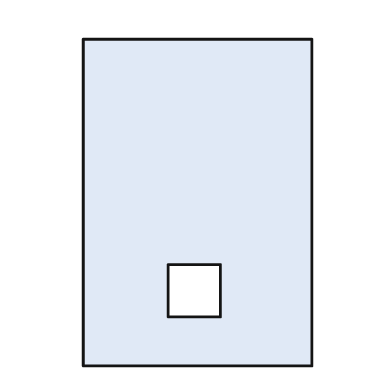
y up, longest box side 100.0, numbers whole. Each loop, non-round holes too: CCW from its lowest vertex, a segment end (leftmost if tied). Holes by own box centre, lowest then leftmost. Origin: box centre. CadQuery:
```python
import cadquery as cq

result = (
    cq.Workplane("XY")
    .moveTo(-35.0, -50.0)
    .lineTo(35.0, -50.0)
    .lineTo(35.0, 50.0)
    .lineTo(-35.0, 50.0)
    .close()
    .moveTo(-9.0, -35.0)
    .lineTo(7.0, -35.0)
    .lineTo(7.0, -19.0)
    .lineTo(-9.0, -19.0)
    .close()
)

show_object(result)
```